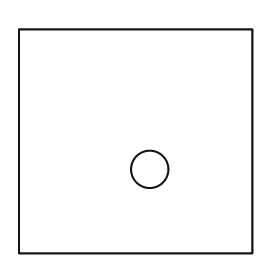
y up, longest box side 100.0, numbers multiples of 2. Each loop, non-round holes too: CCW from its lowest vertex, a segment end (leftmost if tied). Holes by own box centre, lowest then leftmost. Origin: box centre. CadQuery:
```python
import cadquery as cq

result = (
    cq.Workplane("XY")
    .moveTo(-50.0, -48.0)
    .lineTo(50.0, -48.0)
    .lineTo(50.0, 48.0)
    .lineTo(-50.0, 48.0)
    .close()
    .moveTo(6.0, -12.0)
    .circle(8.0)
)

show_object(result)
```